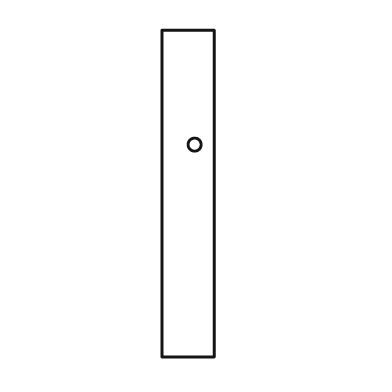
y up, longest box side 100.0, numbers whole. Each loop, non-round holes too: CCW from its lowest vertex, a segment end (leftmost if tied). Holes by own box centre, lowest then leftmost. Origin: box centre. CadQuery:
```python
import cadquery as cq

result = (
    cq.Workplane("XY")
    .moveTo(-8.0, -50.0)
    .lineTo(8.0, -50.0)
    .lineTo(8.0, 50.0)
    .lineTo(-8.0, 50.0)
    .close()
    .moveTo(2.0, 15.0)
    .circle(2.0)
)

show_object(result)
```